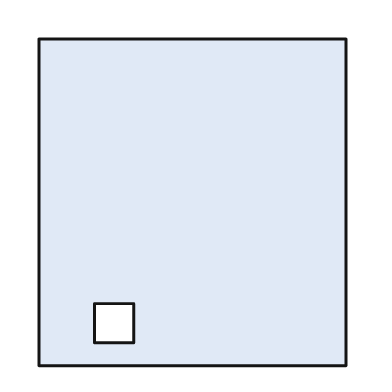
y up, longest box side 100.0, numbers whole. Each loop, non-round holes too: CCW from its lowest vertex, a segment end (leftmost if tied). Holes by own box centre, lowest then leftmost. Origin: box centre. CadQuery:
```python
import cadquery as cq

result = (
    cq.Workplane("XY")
    .moveTo(-47.0, -50.0)
    .lineTo(47.0, -50.0)
    .lineTo(47.0, 50.0)
    .lineTo(-47.0, 50.0)
    .close()
    .moveTo(-30.0, -43.0)
    .lineTo(-18.0, -43.0)
    .lineTo(-18.0, -31.0)
    .lineTo(-30.0, -31.0)
    .close()
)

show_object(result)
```